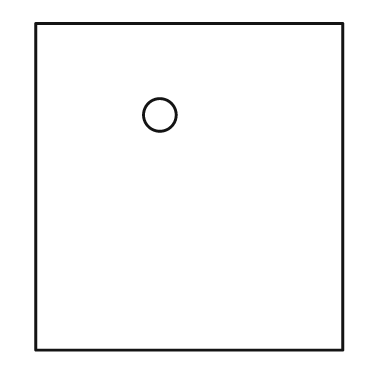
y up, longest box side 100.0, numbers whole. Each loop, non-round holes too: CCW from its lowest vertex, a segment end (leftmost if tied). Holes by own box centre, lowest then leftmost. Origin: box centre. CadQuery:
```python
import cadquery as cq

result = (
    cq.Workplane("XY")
    .moveTo(-47.0, -50.0)
    .lineTo(47.0, -50.0)
    .lineTo(47.0, 50.0)
    .lineTo(-47.0, 50.0)
    .close()
    .moveTo(-9.0, 22.0)
    .circle(5.0)
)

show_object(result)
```